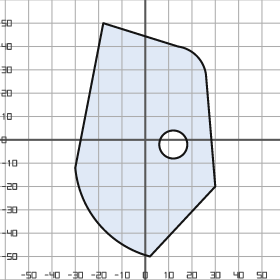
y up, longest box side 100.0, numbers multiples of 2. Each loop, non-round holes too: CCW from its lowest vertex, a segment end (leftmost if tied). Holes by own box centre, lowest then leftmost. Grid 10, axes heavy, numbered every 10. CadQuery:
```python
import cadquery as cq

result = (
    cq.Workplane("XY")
    .moveTo(2.0, -50.0)
    .lineTo(30.0, -20.0)
    .lineTo(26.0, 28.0)
    .threePointArc((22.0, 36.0), (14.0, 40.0))
    .lineTo(-18.0, 50.0)
    .lineTo(-30.0, -12.0)
    .threePointArc((-20.0, -36.0), (2.0, -50.0))
    .close()
    .moveTo(12.0, -2.0)
    .circle(6.0)
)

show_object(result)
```